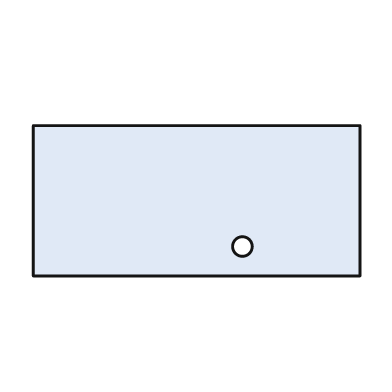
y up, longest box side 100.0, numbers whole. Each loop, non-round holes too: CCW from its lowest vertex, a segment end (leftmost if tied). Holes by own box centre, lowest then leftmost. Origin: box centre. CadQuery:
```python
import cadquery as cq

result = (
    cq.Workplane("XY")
    .moveTo(-50.0, -23.0)
    .lineTo(50.0, -23.0)
    .lineTo(50.0, 23.0)
    .lineTo(-50.0, 23.0)
    .close()
    .moveTo(14.0, -14.0)
    .circle(3.0)
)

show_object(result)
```